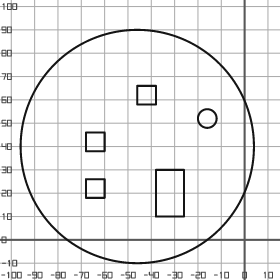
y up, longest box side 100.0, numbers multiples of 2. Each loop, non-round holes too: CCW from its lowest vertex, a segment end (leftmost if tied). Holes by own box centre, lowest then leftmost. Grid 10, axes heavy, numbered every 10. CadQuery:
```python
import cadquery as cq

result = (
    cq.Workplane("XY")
    .moveTo(-46.0, 40.0)
    .circle(50.0)
    .moveTo(-38.0, 10.0)
    .lineTo(-26.0, 10.0)
    .lineTo(-26.0, 30.0)
    .lineTo(-38.0, 30.0)
    .close()
    .moveTo(-68.0, 18.0)
    .lineTo(-60.0, 18.0)
    .lineTo(-60.0, 26.0)
    .lineTo(-68.0, 26.0)
    .close()
    .moveTo(-68.0, 38.0)
    .lineTo(-60.0, 38.0)
    .lineTo(-60.0, 46.0)
    .lineTo(-68.0, 46.0)
    .close()
    .moveTo(-16.0, 52.0)
    .circle(4.0)
    .moveTo(-46.0, 58.0)
    .lineTo(-38.0, 58.0)
    .lineTo(-38.0, 66.0)
    .lineTo(-46.0, 66.0)
    .close()
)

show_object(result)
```